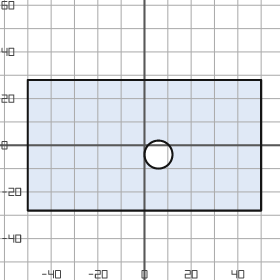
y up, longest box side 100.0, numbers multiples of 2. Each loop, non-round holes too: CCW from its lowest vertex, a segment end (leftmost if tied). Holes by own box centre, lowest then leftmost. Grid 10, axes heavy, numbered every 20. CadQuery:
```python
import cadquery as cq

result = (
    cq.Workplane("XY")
    .moveTo(-50.0, -28.0)
    .lineTo(50.0, -28.0)
    .lineTo(50.0, 28.0)
    .lineTo(-50.0, 28.0)
    .close()
    .moveTo(6.0, -4.0)
    .circle(6.0)
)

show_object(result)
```